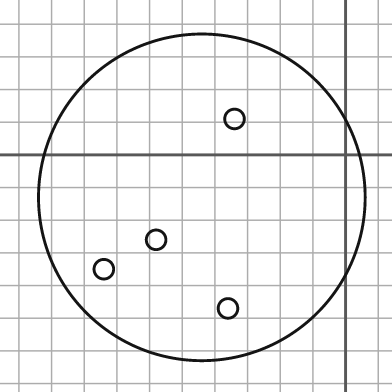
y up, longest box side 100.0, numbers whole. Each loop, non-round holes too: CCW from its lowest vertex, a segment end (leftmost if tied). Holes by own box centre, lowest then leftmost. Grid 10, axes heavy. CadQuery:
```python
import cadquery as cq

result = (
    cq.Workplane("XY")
    .moveTo(-44.0, -13.0)
    .circle(50.0)
    .moveTo(-36.0, -47.0)
    .circle(3.0)
    .moveTo(-74.0, -35.0)
    .circle(3.0)
    .moveTo(-58.0, -26.0)
    .circle(3.0)
    .moveTo(-34.0, 11.0)
    .circle(3.0)
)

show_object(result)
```